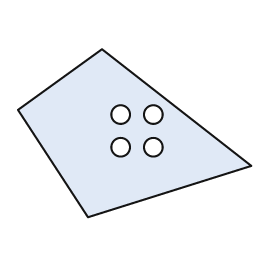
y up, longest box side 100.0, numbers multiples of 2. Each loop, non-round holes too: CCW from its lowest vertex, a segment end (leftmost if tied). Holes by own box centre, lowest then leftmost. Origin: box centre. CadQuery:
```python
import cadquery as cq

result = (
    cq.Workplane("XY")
    .moveTo(-20.0, -36.0)
    .lineTo(50.0, -14.0)
    .lineTo(-14.0, 36.0)
    .lineTo(-50.0, 10.0)
    .close()
    .moveTo(-6.0, -6.0)
    .circle(4.0)
    .moveTo(8.0, -6.0)
    .circle(4.0)
    .moveTo(-6.0, 8.0)
    .circle(4.0)
    .moveTo(8.0, 8.0)
    .circle(4.0)
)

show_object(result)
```